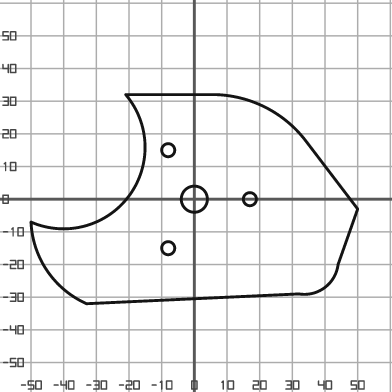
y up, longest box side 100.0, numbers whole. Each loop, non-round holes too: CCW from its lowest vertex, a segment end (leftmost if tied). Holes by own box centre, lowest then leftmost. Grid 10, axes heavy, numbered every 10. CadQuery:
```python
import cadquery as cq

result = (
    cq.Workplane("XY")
    .moveTo(-33.0, -32.0)
    .lineTo(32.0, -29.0)
    .threePointArc((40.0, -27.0), (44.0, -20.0))
    .lineTo(50.0, -3.0)
    .lineTo(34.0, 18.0)
    .threePointArc((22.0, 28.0), (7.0, 32.0))
    .lineTo(-21.0, 32.0)
    .threePointArc((-20.0, 1.0), (-50.0, -7.0))
    .threePointArc((-45.0, -22.0), (-33.0, -32.0))
    .close()
    .moveTo(-8.0, -15.0)
    .circle(2.0)
    .moveTo(0.0, 0.0)
    .circle(4.0)
    .moveTo(17.0, 0.0)
    .circle(2.0)
    .moveTo(-8.0, 15.0)
    .circle(2.0)
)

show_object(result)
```